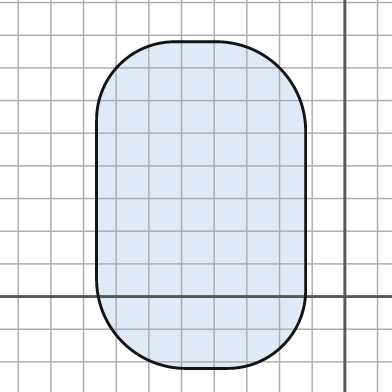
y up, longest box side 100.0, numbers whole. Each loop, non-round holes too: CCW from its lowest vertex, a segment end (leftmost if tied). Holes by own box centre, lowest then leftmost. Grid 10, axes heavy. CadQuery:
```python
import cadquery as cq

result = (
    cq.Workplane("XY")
    .moveTo(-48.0, -22.0)
    .lineTo(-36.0, -22.0)
    .threePointArc((-19.0, -15.0), (-12.0, 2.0))
    .lineTo(-12.0, 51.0)
    .threePointArc((-20.0, 70.0), (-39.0, 78.0))
    .lineTo(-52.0, 78.0)
    .threePointArc((-69.0, 71.0), (-76.0, 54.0))
    .lineTo(-76.0, 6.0)
    .threePointArc((-68.0, -14.0), (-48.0, -22.0))
    .close()
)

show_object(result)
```